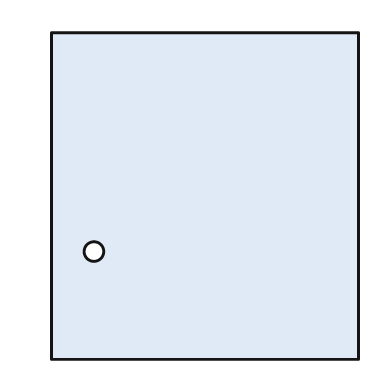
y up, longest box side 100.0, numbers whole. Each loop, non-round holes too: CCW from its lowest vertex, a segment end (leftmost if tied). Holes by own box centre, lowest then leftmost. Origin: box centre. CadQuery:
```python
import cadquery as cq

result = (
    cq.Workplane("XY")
    .moveTo(-47.0, -50.0)
    .lineTo(47.0, -50.0)
    .lineTo(47.0, 50.0)
    .lineTo(-47.0, 50.0)
    .close()
    .moveTo(-34.0, -17.0)
    .circle(3.0)
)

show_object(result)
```